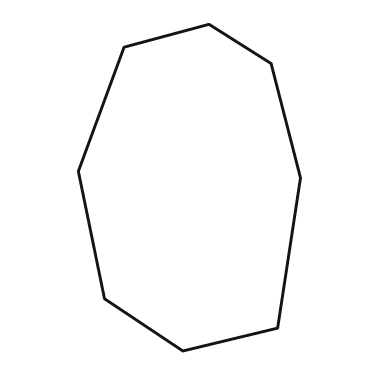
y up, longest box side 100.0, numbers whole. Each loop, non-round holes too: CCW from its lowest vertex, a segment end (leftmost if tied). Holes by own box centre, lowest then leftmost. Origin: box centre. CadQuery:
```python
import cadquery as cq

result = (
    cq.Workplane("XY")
    .moveTo(-2.0, -50.0)
    .lineTo(27.0, -43.0)
    .lineTo(34.0, 3.0)
    .lineTo(25.0, 38.0)
    .lineTo(6.0, 50.0)
    .lineTo(-20.0, 43.0)
    .lineTo(-34.0, 5.0)
    .lineTo(-26.0, -34.0)
    .close()
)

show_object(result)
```